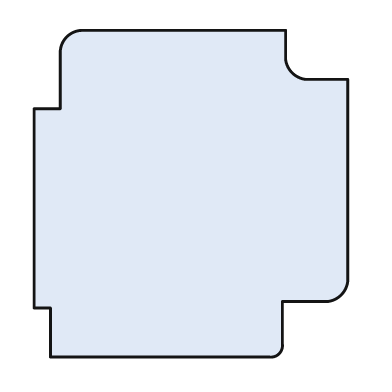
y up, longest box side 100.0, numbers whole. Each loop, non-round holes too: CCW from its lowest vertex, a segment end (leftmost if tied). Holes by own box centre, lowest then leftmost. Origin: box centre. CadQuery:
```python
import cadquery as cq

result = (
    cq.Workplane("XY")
    .moveTo(-43.0, -50.0)
    .lineTo(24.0, -50.0)
    .threePointArc((27.0, -49.0), (28.0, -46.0))
    .lineTo(28.0, -33.0)
    .lineTo(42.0, -33.0)
    .threePointArc((46.0, -31.0), (48.0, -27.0))
    .lineTo(48.0, 35.0)
    .lineTo(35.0, 35.0)
    .threePointArc((31.0, 37.0), (29.0, 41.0))
    .lineTo(29.0, 50.0)
    .lineTo(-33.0, 50.0)
    .threePointArc((-38.0, 48.0), (-40.0, 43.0))
    .lineTo(-40.0, 26.0)
    .lineTo(-48.0, 26.0)
    .lineTo(-48.0, -35.0)
    .lineTo(-43.0, -35.0)
    .close()
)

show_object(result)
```